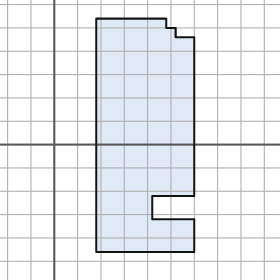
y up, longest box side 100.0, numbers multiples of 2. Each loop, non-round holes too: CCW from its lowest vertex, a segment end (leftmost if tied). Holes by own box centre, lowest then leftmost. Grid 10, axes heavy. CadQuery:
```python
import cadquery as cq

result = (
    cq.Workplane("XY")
    .moveTo(18.0, -46.0)
    .lineTo(60.0, -46.0)
    .lineTo(60.0, -32.0)
    .lineTo(42.0, -32.0)
    .lineTo(42.0, -22.0)
    .lineTo(60.0, -22.0)
    .lineTo(60.0, 46.0)
    .lineTo(52.0, 46.0)
    .lineTo(52.0, 50.0)
    .lineTo(48.0, 50.0)
    .lineTo(48.0, 54.0)
    .lineTo(18.0, 54.0)
    .close()
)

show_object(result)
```